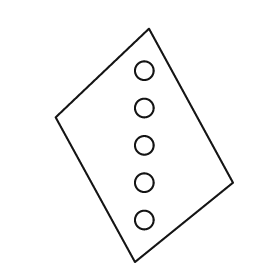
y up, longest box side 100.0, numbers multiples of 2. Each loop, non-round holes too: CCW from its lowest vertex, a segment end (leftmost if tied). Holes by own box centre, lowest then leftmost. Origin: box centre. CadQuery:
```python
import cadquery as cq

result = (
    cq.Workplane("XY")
    .moveTo(-4.0, -50.0)
    .lineTo(38.0, -16.0)
    .lineTo(2.0, 50.0)
    .lineTo(-38.0, 12.0)
    .close()
    .moveTo(0.0, -32.0)
    .circle(4.0)
    .moveTo(0.0, -16.0)
    .circle(4.0)
    .moveTo(0.0, 0.0)
    .circle(4.0)
    .moveTo(0.0, 16.0)
    .circle(4.0)
    .moveTo(0.0, 32.0)
    .circle(4.0)
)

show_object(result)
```